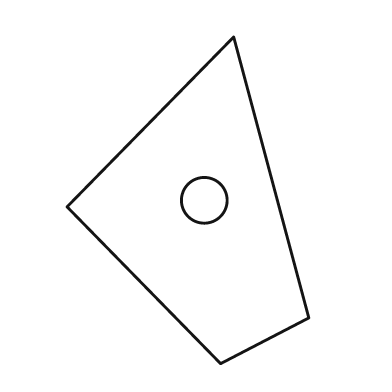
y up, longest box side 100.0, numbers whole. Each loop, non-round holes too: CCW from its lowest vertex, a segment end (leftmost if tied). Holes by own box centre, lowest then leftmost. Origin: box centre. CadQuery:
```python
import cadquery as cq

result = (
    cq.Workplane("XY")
    .moveTo(10.0, -50.0)
    .lineTo(37.0, -36.0)
    .lineTo(14.0, 50.0)
    .lineTo(-37.0, -2.0)
    .close()
    .moveTo(5.0, 0.0)
    .circle(7.0)
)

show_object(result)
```